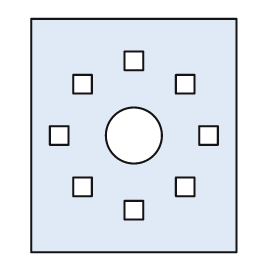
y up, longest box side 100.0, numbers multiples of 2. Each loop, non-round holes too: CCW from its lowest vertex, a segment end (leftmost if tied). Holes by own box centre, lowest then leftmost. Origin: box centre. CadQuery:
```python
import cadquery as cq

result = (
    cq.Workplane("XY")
    .moveTo(-44.0, -50.0)
    .lineTo(44.0, -50.0)
    .lineTo(44.0, 50.0)
    .lineTo(-44.0, 50.0)
    .close()
    .moveTo(-4.0, -36.0)
    .lineTo(4.0, -36.0)
    .lineTo(4.0, -28.0)
    .lineTo(-4.0, -28.0)
    .close()
    .moveTo(-26.0, -26.0)
    .lineTo(-18.0, -26.0)
    .lineTo(-18.0, -18.0)
    .lineTo(-26.0, -18.0)
    .close()
    .moveTo(18.0, -26.0)
    .lineTo(26.0, -26.0)
    .lineTo(26.0, -18.0)
    .lineTo(18.0, -18.0)
    .close()
    .moveTo(-36.0, -4.0)
    .lineTo(-28.0, -4.0)
    .lineTo(-28.0, 4.0)
    .lineTo(-36.0, 4.0)
    .close()
    .moveTo(0.0, 0.0)
    .circle(12.0)
    .moveTo(28.0, -4.0)
    .lineTo(36.0, -4.0)
    .lineTo(36.0, 4.0)
    .lineTo(28.0, 4.0)
    .close()
    .moveTo(-26.0, 18.0)
    .lineTo(-18.0, 18.0)
    .lineTo(-18.0, 26.0)
    .lineTo(-26.0, 26.0)
    .close()
    .moveTo(18.0, 18.0)
    .lineTo(26.0, 18.0)
    .lineTo(26.0, 26.0)
    .lineTo(18.0, 26.0)
    .close()
    .moveTo(-4.0, 28.0)
    .lineTo(4.0, 28.0)
    .lineTo(4.0, 36.0)
    .lineTo(-4.0, 36.0)
    .close()
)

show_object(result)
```